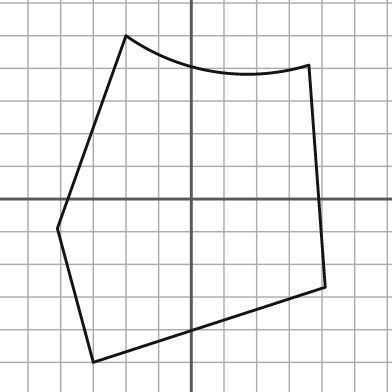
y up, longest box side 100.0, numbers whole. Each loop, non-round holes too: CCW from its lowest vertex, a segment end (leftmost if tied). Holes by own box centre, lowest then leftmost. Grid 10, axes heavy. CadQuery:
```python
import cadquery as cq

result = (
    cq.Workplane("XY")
    .moveTo(-30.0, -50.0)
    .lineTo(41.0, -27.0)
    .lineTo(36.0, 41.0)
    .threePointArc((7.0, 39.0), (-20.0, 50.0))
    .lineTo(-41.0, -9.0)
    .close()
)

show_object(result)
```